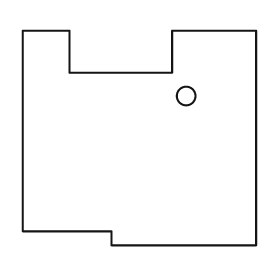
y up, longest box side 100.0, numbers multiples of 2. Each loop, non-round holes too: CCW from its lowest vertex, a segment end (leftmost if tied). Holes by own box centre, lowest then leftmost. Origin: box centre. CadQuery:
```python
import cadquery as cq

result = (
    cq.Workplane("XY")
    .moveTo(-12.0, -46.0)
    .lineTo(50.0, -46.0)
    .lineTo(50.0, 46.0)
    .lineTo(14.0, 46.0)
    .lineTo(14.0, 28.0)
    .lineTo(-30.0, 28.0)
    .lineTo(-30.0, 46.0)
    .lineTo(-50.0, 46.0)
    .lineTo(-50.0, -40.0)
    .lineTo(-12.0, -40.0)
    .close()
    .moveTo(20.0, 18.0)
    .circle(4.0)
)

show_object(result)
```